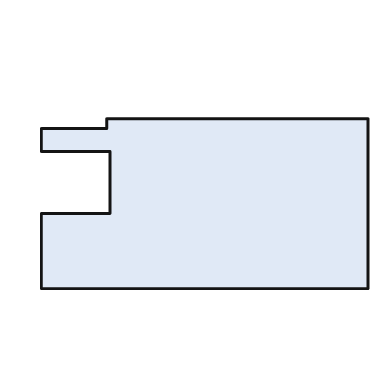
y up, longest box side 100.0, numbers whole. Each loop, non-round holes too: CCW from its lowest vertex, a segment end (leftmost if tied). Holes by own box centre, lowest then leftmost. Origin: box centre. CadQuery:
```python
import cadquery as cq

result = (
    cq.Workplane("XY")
    .moveTo(-50.0, -26.0)
    .lineTo(50.0, -26.0)
    .lineTo(50.0, 26.0)
    .lineTo(-30.0, 26.0)
    .lineTo(-30.0, 23.0)
    .lineTo(-50.0, 23.0)
    .lineTo(-50.0, 16.0)
    .lineTo(-29.0, 16.0)
    .lineTo(-29.0, -3.0)
    .lineTo(-50.0, -3.0)
    .close()
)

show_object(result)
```